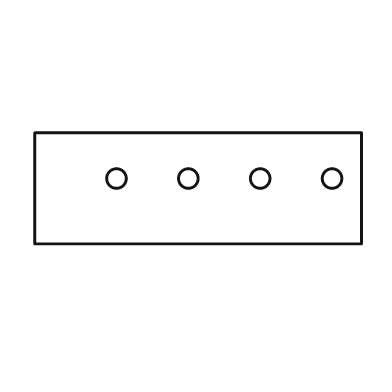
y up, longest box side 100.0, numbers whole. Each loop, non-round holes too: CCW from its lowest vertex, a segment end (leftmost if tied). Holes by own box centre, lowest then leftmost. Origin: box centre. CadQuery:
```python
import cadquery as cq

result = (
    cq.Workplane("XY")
    .moveTo(-50.0, -17.0)
    .lineTo(50.0, -17.0)
    .lineTo(50.0, 17.0)
    .lineTo(-50.0, 17.0)
    .close()
    .moveTo(-25.0, 3.0)
    .circle(3.0)
    .moveTo(-3.0, 3.0)
    .circle(3.0)
    .moveTo(19.0, 3.0)
    .circle(3.0)
    .moveTo(41.0, 3.0)
    .circle(3.0)
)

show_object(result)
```